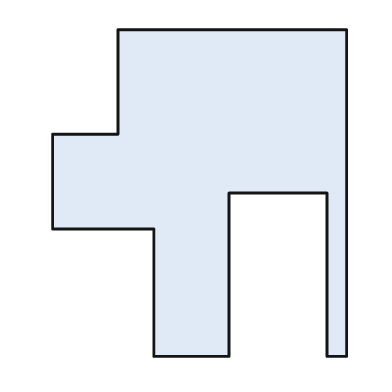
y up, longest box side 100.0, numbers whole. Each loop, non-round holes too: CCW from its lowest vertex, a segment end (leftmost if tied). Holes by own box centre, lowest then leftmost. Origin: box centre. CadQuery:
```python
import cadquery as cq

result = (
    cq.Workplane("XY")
    .moveTo(-14.0, -50.0)
    .lineTo(9.0, -50.0)
    .lineTo(9.0, 0.0)
    .lineTo(39.0, 0.0)
    .lineTo(39.0, -50.0)
    .lineTo(45.0, -50.0)
    .lineTo(45.0, 50.0)
    .lineTo(-25.0, 50.0)
    .lineTo(-25.0, 18.0)
    .lineTo(-45.0, 18.0)
    .lineTo(-45.0, -11.0)
    .lineTo(-14.0, -11.0)
    .close()
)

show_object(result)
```